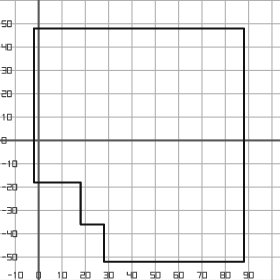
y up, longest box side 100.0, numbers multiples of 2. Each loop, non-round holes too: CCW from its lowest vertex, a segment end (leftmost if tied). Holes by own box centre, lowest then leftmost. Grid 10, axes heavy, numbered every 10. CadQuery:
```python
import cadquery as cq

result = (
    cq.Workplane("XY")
    .moveTo(28.0, -52.0)
    .lineTo(88.0, -52.0)
    .lineTo(88.0, 48.0)
    .lineTo(-2.0, 48.0)
    .lineTo(-2.0, -18.0)
    .lineTo(18.0, -18.0)
    .lineTo(18.0, -36.0)
    .lineTo(28.0, -36.0)
    .close()
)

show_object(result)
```